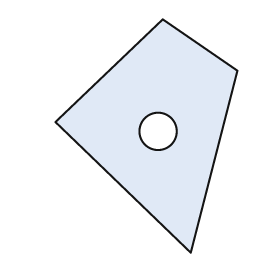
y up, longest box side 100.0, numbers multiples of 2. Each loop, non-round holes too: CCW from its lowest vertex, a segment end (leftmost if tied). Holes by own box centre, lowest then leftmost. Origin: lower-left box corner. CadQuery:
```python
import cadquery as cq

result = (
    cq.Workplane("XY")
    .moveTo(58.0, 0.0)
    .lineTo(78.0, 78.0)
    .lineTo(46.0, 100.0)
    .lineTo(0.0, 56.0)
    .close()
    .moveTo(44.0, 52.0)
    .circle(8.0)
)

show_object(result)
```